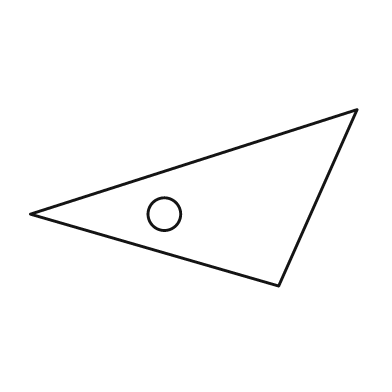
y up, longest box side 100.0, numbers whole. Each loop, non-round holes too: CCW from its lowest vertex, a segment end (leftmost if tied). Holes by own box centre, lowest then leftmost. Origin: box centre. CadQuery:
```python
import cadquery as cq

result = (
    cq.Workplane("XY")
    .moveTo(26.0, -27.0)
    .lineTo(50.0, 27.0)
    .lineTo(-50.0, -5.0)
    .close()
    .moveTo(-9.0, -5.0)
    .circle(5.0)
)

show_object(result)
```